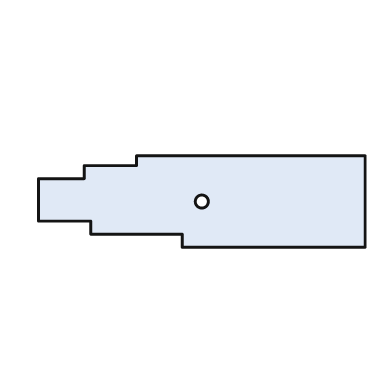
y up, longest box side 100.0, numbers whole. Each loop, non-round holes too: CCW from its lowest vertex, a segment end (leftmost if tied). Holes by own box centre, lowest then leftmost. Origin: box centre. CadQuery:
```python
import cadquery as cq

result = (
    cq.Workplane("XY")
    .moveTo(-6.0, -14.0)
    .lineTo(50.0, -14.0)
    .lineTo(50.0, 14.0)
    .lineTo(-20.0, 14.0)
    .lineTo(-20.0, 11.0)
    .lineTo(-36.0, 11.0)
    .lineTo(-36.0, 7.0)
    .lineTo(-50.0, 7.0)
    .lineTo(-50.0, -6.0)
    .lineTo(-34.0, -6.0)
    .lineTo(-34.0, -10.0)
    .lineTo(-6.0, -10.0)
    .close()
    .moveTo(0.0, 0.0)
    .circle(2.0)
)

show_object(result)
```